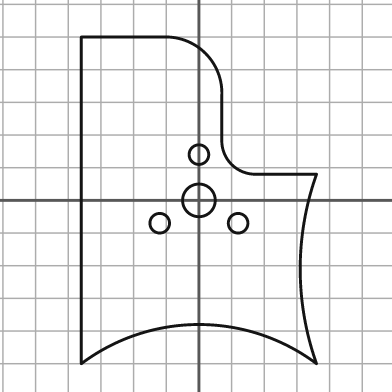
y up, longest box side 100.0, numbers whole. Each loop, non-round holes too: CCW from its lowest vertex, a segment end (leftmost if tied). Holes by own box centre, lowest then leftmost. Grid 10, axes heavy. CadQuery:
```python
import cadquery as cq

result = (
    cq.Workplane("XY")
    .moveTo(-36.0, -50.0)
    .threePointArc((0.0, -38.0), (36.0, -50.0))
    .threePointArc((31.0, -21.0), (36.0, 8.0))
    .lineTo(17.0, 8.0)
    .threePointArc((10.0, 11.0), (7.0, 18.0))
    .lineTo(7.0, 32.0)
    .threePointArc((2.0, 45.0), (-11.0, 50.0))
    .lineTo(-36.0, 50.0)
    .close()
    .moveTo(-12.0, -7.0)
    .circle(3.0)
    .moveTo(12.0, -7.0)
    .circle(3.0)
    .moveTo(0.0, 0.0)
    .circle(5.0)
    .moveTo(0.0, 14.0)
    .circle(3.0)
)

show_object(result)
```